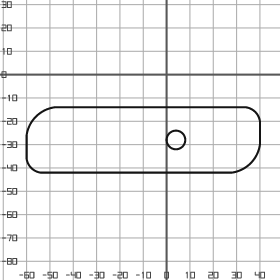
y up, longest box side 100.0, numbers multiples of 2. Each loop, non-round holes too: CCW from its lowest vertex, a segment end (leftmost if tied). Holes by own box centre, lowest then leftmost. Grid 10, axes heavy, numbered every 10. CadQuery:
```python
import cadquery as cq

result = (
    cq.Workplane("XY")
    .moveTo(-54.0, -42.0)
    .lineTo(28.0, -42.0)
    .threePointArc((36.0, -38.0), (40.0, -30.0))
    .lineTo(40.0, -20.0)
    .threePointArc((38.0, -16.0), (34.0, -14.0))
    .lineTo(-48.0, -14.0)
    .threePointArc((-56.0, -18.0), (-60.0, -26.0))
    .lineTo(-60.0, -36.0)
    .threePointArc((-58.0, -40.0), (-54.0, -42.0))
    .close()
    .moveTo(4.0, -28.0)
    .circle(4.0)
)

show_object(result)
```